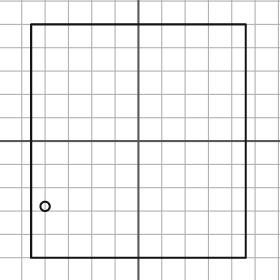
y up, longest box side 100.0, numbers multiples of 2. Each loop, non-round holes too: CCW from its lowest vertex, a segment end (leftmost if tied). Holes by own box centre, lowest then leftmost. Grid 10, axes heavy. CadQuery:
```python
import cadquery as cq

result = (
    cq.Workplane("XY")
    .moveTo(-46.0, -50.0)
    .lineTo(46.0, -50.0)
    .lineTo(46.0, 50.0)
    .lineTo(-46.0, 50.0)
    .close()
    .moveTo(-40.0, -28.0)
    .circle(2.0)
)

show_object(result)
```